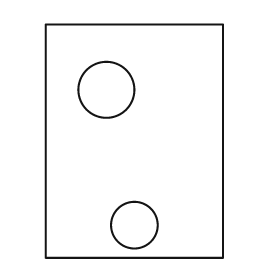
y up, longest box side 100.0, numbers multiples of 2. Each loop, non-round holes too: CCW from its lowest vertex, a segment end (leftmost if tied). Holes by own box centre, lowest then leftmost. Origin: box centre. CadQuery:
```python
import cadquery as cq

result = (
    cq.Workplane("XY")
    .moveTo(-38.0, -50.0)
    .lineTo(38.0, -50.0)
    .lineTo(38.0, 50.0)
    .lineTo(-38.0, 50.0)
    .close()
    .moveTo(0.0, -36.0)
    .circle(10.0)
    .moveTo(-12.0, 22.0)
    .circle(12.0)
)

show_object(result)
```